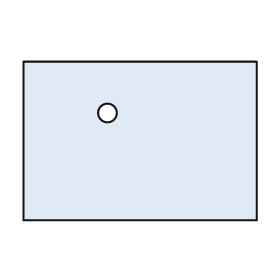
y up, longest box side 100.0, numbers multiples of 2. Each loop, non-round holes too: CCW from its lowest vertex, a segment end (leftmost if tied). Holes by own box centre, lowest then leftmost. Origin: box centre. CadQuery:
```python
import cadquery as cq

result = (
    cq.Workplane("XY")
    .moveTo(-50.0, -34.0)
    .lineTo(50.0, -34.0)
    .lineTo(50.0, 34.0)
    .lineTo(-50.0, 34.0)
    .close()
    .moveTo(-14.0, 12.0)
    .circle(4.0)
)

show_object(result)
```